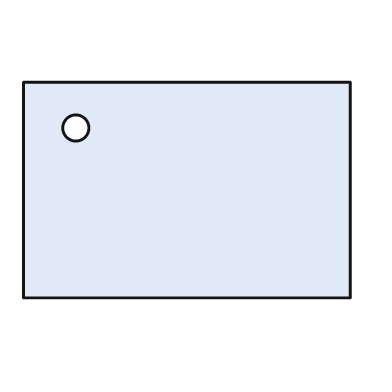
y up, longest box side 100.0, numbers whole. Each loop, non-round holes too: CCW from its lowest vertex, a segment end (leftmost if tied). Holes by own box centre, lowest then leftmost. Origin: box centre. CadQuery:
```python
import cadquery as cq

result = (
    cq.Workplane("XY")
    .moveTo(-50.0, -33.0)
    .lineTo(50.0, -33.0)
    .lineTo(50.0, 33.0)
    .lineTo(-50.0, 33.0)
    .close()
    .moveTo(-34.0, 19.0)
    .circle(4.0)
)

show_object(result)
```